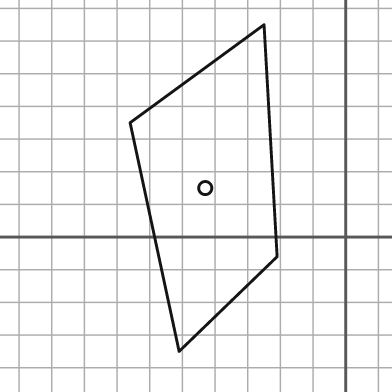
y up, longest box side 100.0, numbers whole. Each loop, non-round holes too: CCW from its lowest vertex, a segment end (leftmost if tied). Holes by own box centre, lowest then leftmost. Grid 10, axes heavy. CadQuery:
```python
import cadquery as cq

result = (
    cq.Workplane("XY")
    .moveTo(-51.0, -35.0)
    .lineTo(-21.0, -6.0)
    .lineTo(-25.0, 65.0)
    .lineTo(-66.0, 35.0)
    .close()
    .moveTo(-43.0, 15.0)
    .circle(2.0)
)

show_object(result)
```